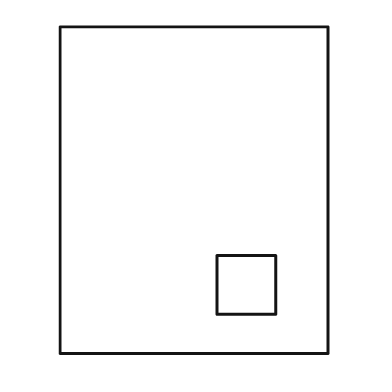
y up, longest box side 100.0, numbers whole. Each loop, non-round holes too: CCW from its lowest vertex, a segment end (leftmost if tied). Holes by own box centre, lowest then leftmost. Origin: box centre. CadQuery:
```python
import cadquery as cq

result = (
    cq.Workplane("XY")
    .moveTo(-41.0, -50.0)
    .lineTo(41.0, -50.0)
    .lineTo(41.0, 50.0)
    .lineTo(-41.0, 50.0)
    .close()
    .moveTo(7.0, -38.0)
    .lineTo(25.0, -38.0)
    .lineTo(25.0, -20.0)
    .lineTo(7.0, -20.0)
    .close()
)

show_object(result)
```